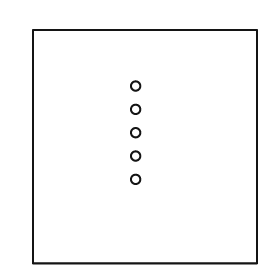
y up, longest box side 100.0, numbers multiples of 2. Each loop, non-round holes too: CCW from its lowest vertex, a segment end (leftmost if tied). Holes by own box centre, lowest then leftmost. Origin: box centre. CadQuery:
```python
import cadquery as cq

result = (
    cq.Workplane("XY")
    .moveTo(-48.0, -50.0)
    .lineTo(48.0, -50.0)
    .lineTo(48.0, 50.0)
    .lineTo(-48.0, 50.0)
    .close()
    .moveTo(-4.0, -14.0)
    .circle(2.0)
    .moveTo(-4.0, -4.0)
    .circle(2.0)
    .moveTo(-4.0, 6.0)
    .circle(2.0)
    .moveTo(-4.0, 16.0)
    .circle(2.0)
    .moveTo(-4.0, 26.0)
    .circle(2.0)
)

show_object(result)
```